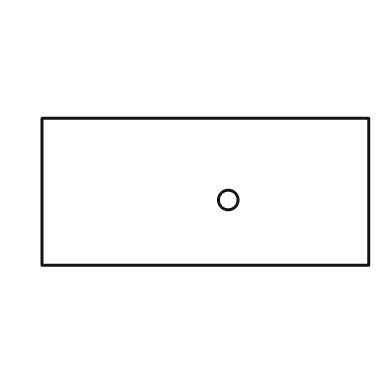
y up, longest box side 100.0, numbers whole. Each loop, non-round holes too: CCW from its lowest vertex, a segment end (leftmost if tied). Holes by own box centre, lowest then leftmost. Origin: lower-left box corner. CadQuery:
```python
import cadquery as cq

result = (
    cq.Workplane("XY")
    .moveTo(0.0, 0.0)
    .lineTo(100.0, 0.0)
    .lineTo(100.0, 45.0)
    .lineTo(0.0, 45.0)
    .close()
    .moveTo(57.0, 20.0)
    .circle(3.0)
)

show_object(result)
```